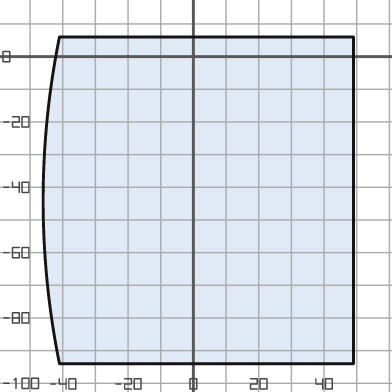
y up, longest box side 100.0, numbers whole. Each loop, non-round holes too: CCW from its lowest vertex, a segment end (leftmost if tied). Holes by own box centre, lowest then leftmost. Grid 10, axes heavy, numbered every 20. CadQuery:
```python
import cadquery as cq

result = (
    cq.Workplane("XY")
    .moveTo(-41.0, -94.0)
    .lineTo(49.0, -94.0)
    .lineTo(49.0, 6.0)
    .lineTo(-41.0, 6.0)
    .threePointArc((-46.0, -44.0), (-41.0, -94.0))
    .close()
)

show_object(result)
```